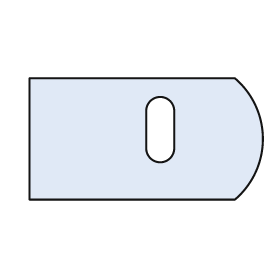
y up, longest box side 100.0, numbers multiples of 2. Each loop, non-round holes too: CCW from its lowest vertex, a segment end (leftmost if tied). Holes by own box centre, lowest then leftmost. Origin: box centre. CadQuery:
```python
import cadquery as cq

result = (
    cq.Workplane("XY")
    .moveTo(-50.0, -26.0)
    .lineTo(38.0, -26.0)
    .threePointArc((50.0, 0.0), (38.0, 26.0))
    .lineTo(-50.0, 26.0)
    .close()
    .moveTo(0.0, -4.0)
    .threePointArc((6.0, -10.0), (12.0, -4.0))
    .lineTo(12.0, 12.0)
    .threePointArc((6.0, 18.0), (0.0, 12.0))
    .close()
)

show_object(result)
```